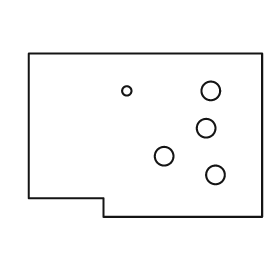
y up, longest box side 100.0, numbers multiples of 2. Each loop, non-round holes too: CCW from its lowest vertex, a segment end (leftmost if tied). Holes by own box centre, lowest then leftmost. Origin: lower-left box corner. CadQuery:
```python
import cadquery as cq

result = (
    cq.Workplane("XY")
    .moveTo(32.0, 0.0)
    .lineTo(100.0, 0.0)
    .lineTo(100.0, 70.0)
    .lineTo(0.0, 70.0)
    .lineTo(0.0, 8.0)
    .lineTo(32.0, 8.0)
    .close()
    .moveTo(80.0, 18.0)
    .circle(4.0)
    .moveTo(58.0, 26.0)
    .circle(4.0)
    .moveTo(76.0, 38.0)
    .circle(4.0)
    .moveTo(42.0, 54.0)
    .circle(2.0)
    .moveTo(78.0, 54.0)
    .circle(4.0)
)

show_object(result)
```